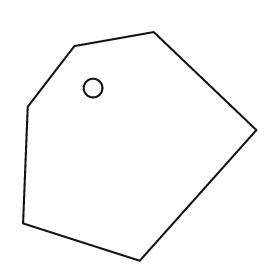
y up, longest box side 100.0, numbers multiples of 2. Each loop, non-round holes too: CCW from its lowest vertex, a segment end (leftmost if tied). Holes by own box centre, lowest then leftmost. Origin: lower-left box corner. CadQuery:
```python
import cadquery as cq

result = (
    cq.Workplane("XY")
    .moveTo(50.0, 0.0)
    .lineTo(100.0, 56.0)
    .lineTo(56.0, 98.0)
    .lineTo(22.0, 92.0)
    .lineTo(2.0, 66.0)
    .lineTo(0.0, 16.0)
    .close()
    .moveTo(30.0, 74.0)
    .circle(4.0)
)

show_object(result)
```